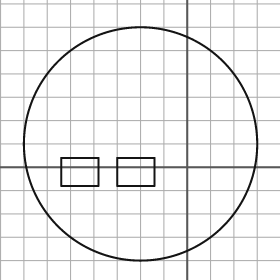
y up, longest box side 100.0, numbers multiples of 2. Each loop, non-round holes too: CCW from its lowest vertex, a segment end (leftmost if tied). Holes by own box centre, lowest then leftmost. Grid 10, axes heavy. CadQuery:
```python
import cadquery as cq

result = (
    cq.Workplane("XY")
    .moveTo(-20.0, 10.0)
    .circle(50.0)
    .moveTo(-54.0, -8.0)
    .lineTo(-38.0, -8.0)
    .lineTo(-38.0, 4.0)
    .lineTo(-54.0, 4.0)
    .close()
    .moveTo(-30.0, -8.0)
    .lineTo(-14.0, -8.0)
    .lineTo(-14.0, 4.0)
    .lineTo(-30.0, 4.0)
    .close()
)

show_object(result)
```